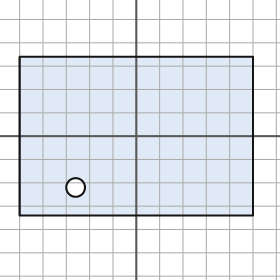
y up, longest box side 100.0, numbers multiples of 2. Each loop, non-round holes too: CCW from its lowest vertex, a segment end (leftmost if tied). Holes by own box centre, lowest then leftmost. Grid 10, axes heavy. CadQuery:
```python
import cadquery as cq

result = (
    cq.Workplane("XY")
    .moveTo(-50.0, -34.0)
    .lineTo(50.0, -34.0)
    .lineTo(50.0, 34.0)
    .lineTo(-50.0, 34.0)
    .close()
    .moveTo(-26.0, -22.0)
    .circle(4.0)
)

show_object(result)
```